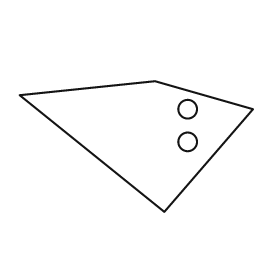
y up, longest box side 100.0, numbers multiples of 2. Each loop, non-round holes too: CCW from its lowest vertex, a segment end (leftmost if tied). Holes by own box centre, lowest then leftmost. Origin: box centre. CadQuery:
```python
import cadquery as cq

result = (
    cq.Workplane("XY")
    .moveTo(12.0, -28.0)
    .lineTo(50.0, 16.0)
    .lineTo(8.0, 28.0)
    .lineTo(-50.0, 22.0)
    .close()
    .moveTo(22.0, 2.0)
    .circle(4.0)
    .moveTo(22.0, 16.0)
    .circle(4.0)
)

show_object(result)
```